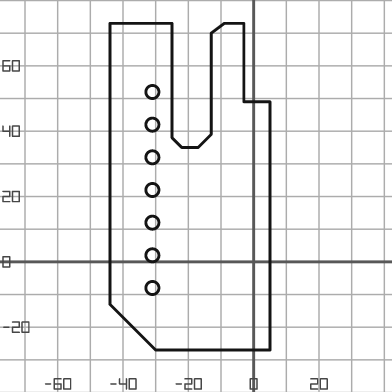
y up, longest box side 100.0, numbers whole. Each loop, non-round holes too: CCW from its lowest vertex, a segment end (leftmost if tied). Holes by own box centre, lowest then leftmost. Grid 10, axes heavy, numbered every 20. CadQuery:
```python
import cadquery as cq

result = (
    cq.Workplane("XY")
    .moveTo(-30.0, -27.0)
    .lineTo(5.0, -27.0)
    .lineTo(5.0, 49.0)
    .lineTo(-3.0, 49.0)
    .lineTo(-3.0, 73.0)
    .lineTo(-9.0, 73.0)
    .lineTo(-13.0, 70.0)
    .lineTo(-13.0, 39.0)
    .lineTo(-17.0, 35.0)
    .lineTo(-22.0, 35.0)
    .lineTo(-25.0, 38.0)
    .lineTo(-25.0, 73.0)
    .lineTo(-44.0, 73.0)
    .lineTo(-44.0, -13.0)
    .close()
    .moveTo(-31.0, -8.0)
    .circle(2.0)
    .moveTo(-31.0, 2.0)
    .circle(2.0)
    .moveTo(-31.0, 12.0)
    .circle(2.0)
    .moveTo(-31.0, 22.0)
    .circle(2.0)
    .moveTo(-31.0, 32.0)
    .circle(2.0)
    .moveTo(-31.0, 42.0)
    .circle(2.0)
    .moveTo(-31.0, 52.0)
    .circle(2.0)
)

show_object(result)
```